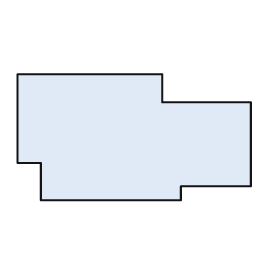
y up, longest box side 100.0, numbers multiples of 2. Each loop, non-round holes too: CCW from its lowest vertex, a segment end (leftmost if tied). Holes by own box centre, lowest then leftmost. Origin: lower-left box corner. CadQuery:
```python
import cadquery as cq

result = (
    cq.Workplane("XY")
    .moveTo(10.0, 0.0)
    .lineTo(70.0, 0.0)
    .lineTo(70.0, 6.0)
    .lineTo(100.0, 6.0)
    .lineTo(100.0, 42.0)
    .lineTo(62.0, 42.0)
    .lineTo(62.0, 54.0)
    .lineTo(0.0, 54.0)
    .lineTo(0.0, 16.0)
    .lineTo(10.0, 16.0)
    .close()
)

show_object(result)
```